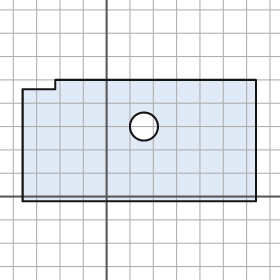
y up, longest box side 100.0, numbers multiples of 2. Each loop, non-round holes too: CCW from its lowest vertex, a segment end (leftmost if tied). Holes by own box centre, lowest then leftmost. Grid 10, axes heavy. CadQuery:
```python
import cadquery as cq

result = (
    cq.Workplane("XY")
    .moveTo(-36.0, -2.0)
    .lineTo(64.0, -2.0)
    .lineTo(64.0, 50.0)
    .lineTo(-22.0, 50.0)
    .lineTo(-22.0, 46.0)
    .lineTo(-36.0, 46.0)
    .close()
    .moveTo(16.0, 30.0)
    .circle(6.0)
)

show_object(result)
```